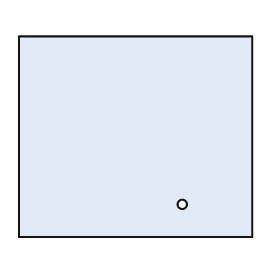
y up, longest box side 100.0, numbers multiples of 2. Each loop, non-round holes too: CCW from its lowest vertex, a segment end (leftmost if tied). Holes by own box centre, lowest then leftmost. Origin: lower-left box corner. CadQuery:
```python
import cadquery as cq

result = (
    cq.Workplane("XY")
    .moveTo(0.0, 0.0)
    .lineTo(100.0, 0.0)
    .lineTo(100.0, 86.0)
    .lineTo(0.0, 86.0)
    .close()
    .moveTo(70.0, 14.0)
    .circle(2.0)
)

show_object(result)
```